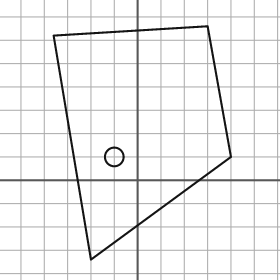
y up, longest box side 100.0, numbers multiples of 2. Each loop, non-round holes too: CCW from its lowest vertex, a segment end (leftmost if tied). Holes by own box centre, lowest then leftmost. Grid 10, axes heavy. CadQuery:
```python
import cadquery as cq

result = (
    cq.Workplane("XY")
    .moveTo(-20.0, -34.0)
    .lineTo(40.0, 10.0)
    .lineTo(30.0, 66.0)
    .lineTo(-36.0, 62.0)
    .close()
    .moveTo(-10.0, 10.0)
    .circle(4.0)
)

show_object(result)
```